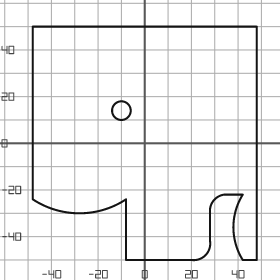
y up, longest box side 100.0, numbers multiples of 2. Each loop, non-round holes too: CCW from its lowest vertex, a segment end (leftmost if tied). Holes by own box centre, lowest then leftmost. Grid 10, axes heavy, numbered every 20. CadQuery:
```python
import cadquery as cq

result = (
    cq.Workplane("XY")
    .moveTo(-8.0, -50.0)
    .lineTo(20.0, -50.0)
    .threePointArc((26.0, -48.0), (28.0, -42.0))
    .lineTo(28.0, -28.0)
    .threePointArc((30.0, -24.0), (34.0, -22.0))
    .lineTo(42.0, -22.0)
    .threePointArc((38.0, -36.0), (42.0, -50.0))
    .lineTo(48.0, -50.0)
    .lineTo(48.0, 50.0)
    .lineTo(-48.0, 50.0)
    .lineTo(-48.0, -24.0)
    .threePointArc((-28.0, -30.0), (-8.0, -24.0))
    .close()
    .moveTo(-10.0, 14.0)
    .circle(4.0)
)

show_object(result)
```